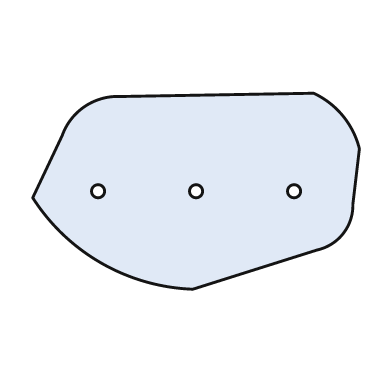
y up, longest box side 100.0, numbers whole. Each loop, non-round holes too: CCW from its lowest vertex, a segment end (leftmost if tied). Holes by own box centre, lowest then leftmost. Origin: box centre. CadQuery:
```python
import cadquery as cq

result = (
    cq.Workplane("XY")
    .moveTo(-1.0, -30.0)
    .lineTo(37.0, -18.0)
    .threePointArc((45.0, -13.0), (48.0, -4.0))
    .lineTo(50.0, 13.0)
    .threePointArc((45.0, 23.0), (36.0, 30.0))
    .lineTo(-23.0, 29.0)
    .threePointArc((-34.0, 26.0), (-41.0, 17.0))
    .lineTo(-50.0, -2.0)
    .threePointArc((-29.0, -22.0), (-1.0, -30.0))
    .close()
    .moveTo(-30.0, 0.0)
    .circle(2.0)
    .moveTo(0.0, 0.0)
    .circle(2.0)
    .moveTo(30.0, 0.0)
    .circle(2.0)
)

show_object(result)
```